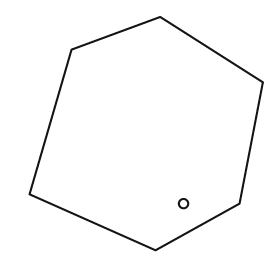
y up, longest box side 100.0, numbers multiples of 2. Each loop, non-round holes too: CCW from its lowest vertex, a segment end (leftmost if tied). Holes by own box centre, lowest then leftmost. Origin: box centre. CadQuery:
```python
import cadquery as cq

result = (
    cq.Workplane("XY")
    .moveTo(4.0, -50.0)
    .lineTo(40.0, -30.0)
    .lineTo(50.0, 22.0)
    .lineTo(6.0, 50.0)
    .lineTo(-32.0, 36.0)
    .lineTo(-50.0, -26.0)
    .close()
    .moveTo(16.0, -30.0)
    .circle(2.0)
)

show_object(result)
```